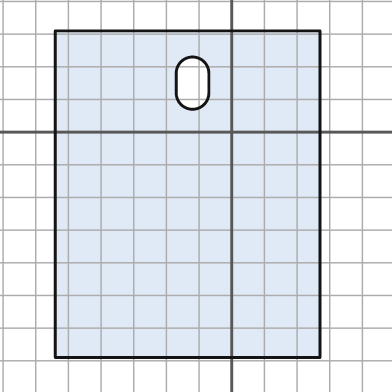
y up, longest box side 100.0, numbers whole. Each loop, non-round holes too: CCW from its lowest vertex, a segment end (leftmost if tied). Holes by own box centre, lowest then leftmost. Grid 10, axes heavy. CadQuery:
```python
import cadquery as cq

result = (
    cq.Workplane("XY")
    .moveTo(-54.0, -69.0)
    .lineTo(27.0, -69.0)
    .lineTo(27.0, 31.0)
    .lineTo(-54.0, 31.0)
    .close()
    .moveTo(-17.0, 12.0)
    .threePointArc((-12.0, 7.0), (-7.0, 12.0))
    .lineTo(-7.0, 18.0)
    .threePointArc((-12.0, 23.0), (-17.0, 18.0))
    .close()
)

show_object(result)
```